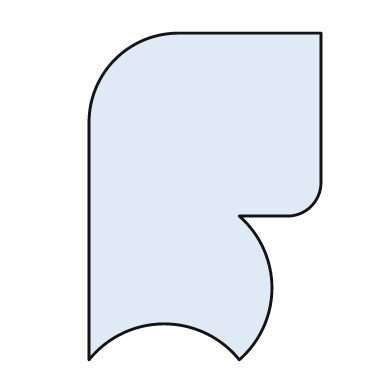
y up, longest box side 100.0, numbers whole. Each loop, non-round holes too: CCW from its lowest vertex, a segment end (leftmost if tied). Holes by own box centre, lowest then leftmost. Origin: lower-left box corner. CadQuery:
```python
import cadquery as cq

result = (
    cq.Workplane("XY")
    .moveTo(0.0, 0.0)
    .threePointArc((23.0, 11.0), (46.0, 0.0))
    .threePointArc((56.0, 22.0), (46.0, 44.0))
    .lineTo(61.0, 44.0)
    .threePointArc((68.0, 47.0), (71.0, 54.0))
    .lineTo(71.0, 100.0)
    .lineTo(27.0, 100.0)
    .threePointArc((8.0, 92.0), (0.0, 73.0))
    .close()
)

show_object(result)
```